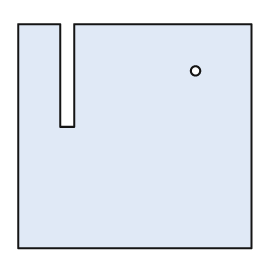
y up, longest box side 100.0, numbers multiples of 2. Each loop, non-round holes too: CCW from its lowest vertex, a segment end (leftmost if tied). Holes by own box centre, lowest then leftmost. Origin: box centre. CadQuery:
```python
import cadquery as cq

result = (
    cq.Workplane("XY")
    .moveTo(-50.0, -48.0)
    .lineTo(50.0, -48.0)
    .lineTo(50.0, 48.0)
    .lineTo(-26.0, 48.0)
    .lineTo(-26.0, 4.0)
    .lineTo(-32.0, 4.0)
    .lineTo(-32.0, 48.0)
    .lineTo(-50.0, 48.0)
    .close()
    .moveTo(26.0, 28.0)
    .circle(2.0)
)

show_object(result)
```